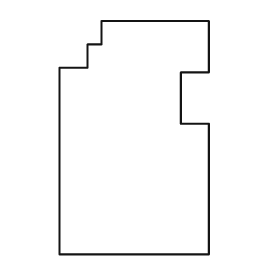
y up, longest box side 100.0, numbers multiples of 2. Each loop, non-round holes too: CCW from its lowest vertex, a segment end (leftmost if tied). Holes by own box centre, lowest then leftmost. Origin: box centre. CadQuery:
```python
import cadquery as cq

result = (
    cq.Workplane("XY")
    .moveTo(-32.0, -50.0)
    .lineTo(32.0, -50.0)
    .lineTo(32.0, 6.0)
    .lineTo(20.0, 6.0)
    .lineTo(20.0, 28.0)
    .lineTo(32.0, 28.0)
    .lineTo(32.0, 50.0)
    .lineTo(-14.0, 50.0)
    .lineTo(-14.0, 40.0)
    .lineTo(-20.0, 40.0)
    .lineTo(-20.0, 30.0)
    .lineTo(-32.0, 30.0)
    .close()
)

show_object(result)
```